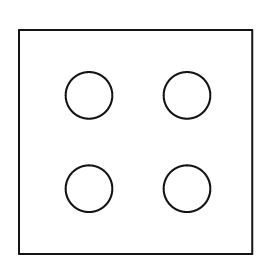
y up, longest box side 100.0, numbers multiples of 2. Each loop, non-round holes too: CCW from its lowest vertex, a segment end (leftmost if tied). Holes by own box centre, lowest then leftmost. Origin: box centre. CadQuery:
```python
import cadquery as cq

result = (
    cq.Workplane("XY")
    .moveTo(-50.0, -48.0)
    .lineTo(50.0, -48.0)
    .lineTo(50.0, 48.0)
    .lineTo(-50.0, 48.0)
    .close()
    .moveTo(-20.0, -20.0)
    .circle(10.0)
    .moveTo(22.0, -20.0)
    .circle(10.0)
    .moveTo(-20.0, 20.0)
    .circle(10.0)
    .moveTo(22.0, 20.0)
    .circle(10.0)
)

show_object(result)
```